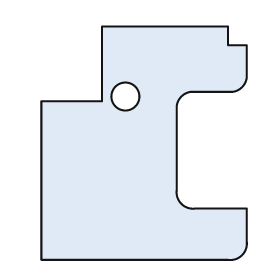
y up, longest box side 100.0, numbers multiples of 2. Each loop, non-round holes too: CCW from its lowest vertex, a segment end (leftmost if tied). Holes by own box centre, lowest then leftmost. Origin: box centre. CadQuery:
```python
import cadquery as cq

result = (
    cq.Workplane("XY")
    .moveTo(-44.0, -50.0)
    .lineTo(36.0, -50.0)
    .threePointArc((42.0, -48.0), (44.0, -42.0))
    .lineTo(44.0, -28.0)
    .lineTo(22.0, -28.0)
    .threePointArc((16.0, -26.0), (14.0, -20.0))
    .lineTo(14.0, 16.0)
    .threePointArc((16.0, 20.0), (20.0, 22.0))
    .lineTo(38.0, 22.0)
    .threePointArc((42.0, 24.0), (44.0, 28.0))
    .lineTo(44.0, 42.0)
    .lineTo(36.0, 42.0)
    .lineTo(36.0, 50.0)
    .lineTo(-18.0, 50.0)
    .lineTo(-18.0, 18.0)
    .lineTo(-44.0, 18.0)
    .close()
    .moveTo(-8.0, 20.0)
    .circle(6.0)
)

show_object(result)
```